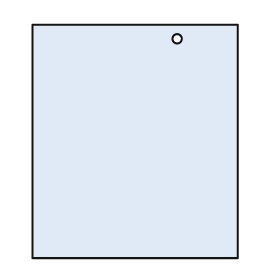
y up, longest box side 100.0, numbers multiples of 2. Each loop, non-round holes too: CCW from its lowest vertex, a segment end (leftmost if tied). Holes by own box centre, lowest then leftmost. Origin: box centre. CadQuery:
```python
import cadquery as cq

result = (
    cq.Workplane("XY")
    .moveTo(-44.0, -50.0)
    .lineTo(44.0, -50.0)
    .lineTo(44.0, 50.0)
    .lineTo(-44.0, 50.0)
    .close()
    .moveTo(18.0, 44.0)
    .circle(2.0)
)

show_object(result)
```